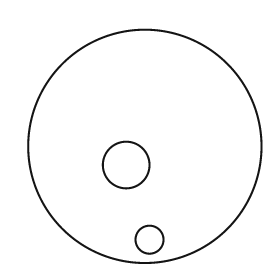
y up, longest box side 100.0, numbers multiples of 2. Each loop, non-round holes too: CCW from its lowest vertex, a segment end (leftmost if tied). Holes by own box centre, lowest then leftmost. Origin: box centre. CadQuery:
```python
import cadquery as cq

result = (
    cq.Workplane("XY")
    .moveTo(0.0, 0.0)
    .circle(50.0)
    .moveTo(2.0, -40.0)
    .circle(6.0)
    .moveTo(-8.0, -8.0)
    .circle(10.0)
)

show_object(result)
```